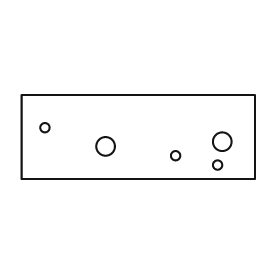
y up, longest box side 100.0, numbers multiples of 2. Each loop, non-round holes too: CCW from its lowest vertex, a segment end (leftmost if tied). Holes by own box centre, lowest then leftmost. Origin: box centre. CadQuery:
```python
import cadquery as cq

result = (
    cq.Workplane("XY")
    .moveTo(-50.0, -18.0)
    .lineTo(50.0, -18.0)
    .lineTo(50.0, 18.0)
    .lineTo(-50.0, 18.0)
    .close()
    .moveTo(34.0, -12.0)
    .circle(2.0)
    .moveTo(16.0, -8.0)
    .circle(2.0)
    .moveTo(-14.0, -4.0)
    .circle(4.0)
    .moveTo(36.0, -2.0)
    .circle(4.0)
    .moveTo(-40.0, 4.0)
    .circle(2.0)
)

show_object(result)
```